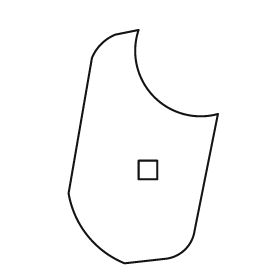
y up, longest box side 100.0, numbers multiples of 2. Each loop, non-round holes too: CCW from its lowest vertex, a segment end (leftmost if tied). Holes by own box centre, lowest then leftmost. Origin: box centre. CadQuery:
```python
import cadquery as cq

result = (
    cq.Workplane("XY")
    .moveTo(-8.0, -50.0)
    .lineTo(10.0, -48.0)
    .threePointArc((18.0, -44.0), (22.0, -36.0))
    .lineTo(32.0, 14.0)
    .threePointArc((4.0, 22.0), (-2.0, 50.0))
    .lineTo(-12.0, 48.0)
    .threePointArc((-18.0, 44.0), (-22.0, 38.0))
    .lineTo(-32.0, -20.0)
    .threePointArc((-24.0, -38.0), (-8.0, -50.0))
    .close()
    .moveTo(-2.0, -14.0)
    .lineTo(6.0, -14.0)
    .lineTo(6.0, -6.0)
    .lineTo(-2.0, -6.0)
    .close()
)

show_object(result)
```